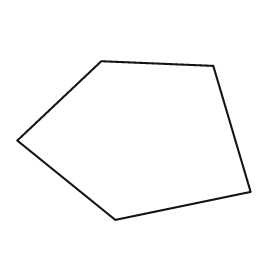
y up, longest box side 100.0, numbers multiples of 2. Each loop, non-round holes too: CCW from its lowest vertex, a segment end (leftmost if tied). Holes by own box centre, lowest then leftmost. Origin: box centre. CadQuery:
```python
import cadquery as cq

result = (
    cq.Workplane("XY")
    .moveTo(-8.0, -34.0)
    .lineTo(50.0, -22.0)
    .lineTo(34.0, 32.0)
    .lineTo(-14.0, 34.0)
    .lineTo(-50.0, 0.0)
    .close()
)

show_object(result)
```